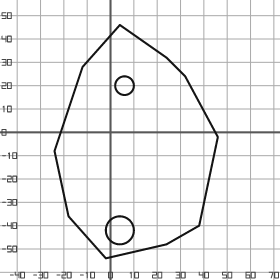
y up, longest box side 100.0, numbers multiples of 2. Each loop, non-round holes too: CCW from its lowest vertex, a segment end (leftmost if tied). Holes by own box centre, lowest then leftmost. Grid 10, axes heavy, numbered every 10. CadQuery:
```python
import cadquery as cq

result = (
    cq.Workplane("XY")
    .moveTo(-2.0, -54.0)
    .lineTo(24.0, -48.0)
    .lineTo(38.0, -40.0)
    .lineTo(46.0, -2.0)
    .lineTo(32.0, 24.0)
    .lineTo(24.0, 32.0)
    .lineTo(4.0, 46.0)
    .lineTo(-12.0, 28.0)
    .lineTo(-24.0, -8.0)
    .lineTo(-18.0, -36.0)
    .close()
    .moveTo(4.0, -42.0)
    .circle(6.0)
    .moveTo(6.0, 20.0)
    .circle(4.0)
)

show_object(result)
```